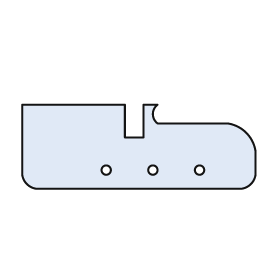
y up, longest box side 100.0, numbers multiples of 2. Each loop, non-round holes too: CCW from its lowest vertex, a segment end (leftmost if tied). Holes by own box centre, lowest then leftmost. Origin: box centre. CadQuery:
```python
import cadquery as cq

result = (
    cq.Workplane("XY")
    .moveTo(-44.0, -18.0)
    .lineTo(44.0, -18.0)
    .threePointArc((48.0, -16.0), (50.0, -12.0))
    .lineTo(50.0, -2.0)
    .threePointArc((46.0, 6.0), (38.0, 10.0))
    .lineTo(8.0, 10.0)
    .threePointArc((6.0, 14.0), (8.0, 18.0))
    .lineTo(2.0, 18.0)
    .lineTo(2.0, 4.0)
    .lineTo(-6.0, 4.0)
    .lineTo(-6.0, 18.0)
    .lineTo(-50.0, 18.0)
    .lineTo(-50.0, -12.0)
    .threePointArc((-48.0, -16.0), (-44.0, -18.0))
    .close()
    .moveTo(-14.0, -10.0)
    .circle(2.0)
    .moveTo(6.0, -10.0)
    .circle(2.0)
    .moveTo(26.0, -10.0)
    .circle(2.0)
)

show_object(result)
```